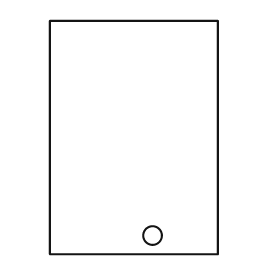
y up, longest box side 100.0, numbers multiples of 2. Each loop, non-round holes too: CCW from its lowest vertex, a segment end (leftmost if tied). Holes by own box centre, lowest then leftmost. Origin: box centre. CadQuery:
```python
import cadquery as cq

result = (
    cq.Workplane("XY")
    .moveTo(-36.0, -50.0)
    .lineTo(36.0, -50.0)
    .lineTo(36.0, 50.0)
    .lineTo(-36.0, 50.0)
    .close()
    .moveTo(8.0, -42.0)
    .circle(4.0)
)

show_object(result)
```